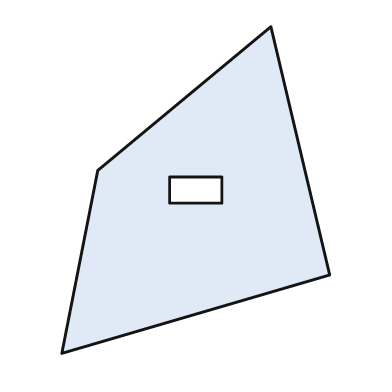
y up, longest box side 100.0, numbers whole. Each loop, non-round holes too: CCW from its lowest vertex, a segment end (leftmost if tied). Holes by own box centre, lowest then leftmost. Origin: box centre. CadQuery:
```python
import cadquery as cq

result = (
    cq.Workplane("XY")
    .moveTo(-41.0, -50.0)
    .lineTo(41.0, -26.0)
    .lineTo(23.0, 50.0)
    .lineTo(-30.0, 6.0)
    .close()
    .moveTo(-8.0, -4.0)
    .lineTo(8.0, -4.0)
    .lineTo(8.0, 4.0)
    .lineTo(-8.0, 4.0)
    .close()
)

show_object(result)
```